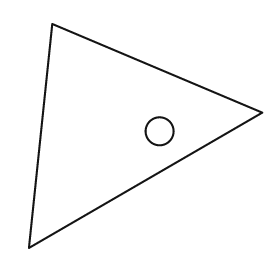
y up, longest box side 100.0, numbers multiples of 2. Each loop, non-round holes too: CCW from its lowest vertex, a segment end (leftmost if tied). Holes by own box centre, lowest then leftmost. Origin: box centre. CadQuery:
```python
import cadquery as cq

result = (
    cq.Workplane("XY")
    .moveTo(-50.0, -48.0)
    .lineTo(50.0, 10.0)
    .lineTo(-40.0, 48.0)
    .close()
    .moveTo(6.0, 2.0)
    .circle(6.0)
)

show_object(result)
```